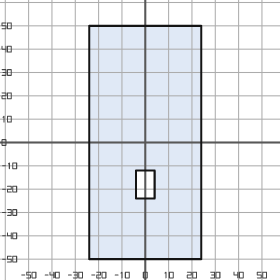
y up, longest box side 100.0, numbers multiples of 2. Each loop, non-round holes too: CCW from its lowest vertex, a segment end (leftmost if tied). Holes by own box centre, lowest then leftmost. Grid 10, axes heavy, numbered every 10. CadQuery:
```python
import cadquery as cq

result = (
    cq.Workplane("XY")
    .moveTo(-24.0, -50.0)
    .lineTo(24.0, -50.0)
    .lineTo(24.0, 50.0)
    .lineTo(-24.0, 50.0)
    .close()
    .moveTo(-4.0, -24.0)
    .lineTo(4.0, -24.0)
    .lineTo(4.0, -12.0)
    .lineTo(-4.0, -12.0)
    .close()
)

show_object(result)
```